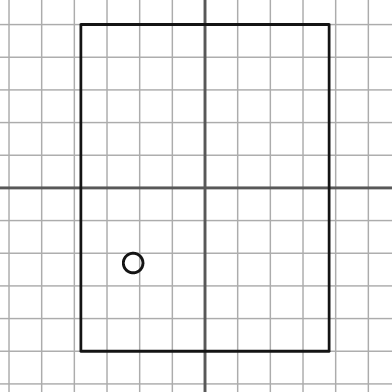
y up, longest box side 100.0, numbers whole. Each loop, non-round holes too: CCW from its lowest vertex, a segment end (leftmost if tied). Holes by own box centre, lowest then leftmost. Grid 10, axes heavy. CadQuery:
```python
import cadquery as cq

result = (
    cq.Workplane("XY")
    .moveTo(-38.0, -50.0)
    .lineTo(38.0, -50.0)
    .lineTo(38.0, 50.0)
    .lineTo(-38.0, 50.0)
    .close()
    .moveTo(-22.0, -23.0)
    .circle(3.0)
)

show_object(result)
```